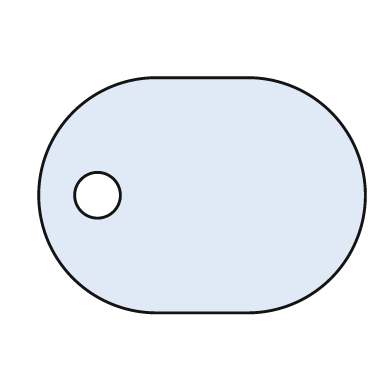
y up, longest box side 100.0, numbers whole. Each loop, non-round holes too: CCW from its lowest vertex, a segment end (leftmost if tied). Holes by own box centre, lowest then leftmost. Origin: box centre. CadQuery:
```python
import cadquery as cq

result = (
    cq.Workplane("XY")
    .moveTo(-14.0, -36.0)
    .lineTo(14.0, -36.0)
    .threePointArc((50.0, 0.0), (14.0, 36.0))
    .lineTo(-14.0, 36.0)
    .threePointArc((-50.0, 0.0), (-14.0, -36.0))
    .close()
    .moveTo(-32.0, 0.0)
    .circle(7.0)
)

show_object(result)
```